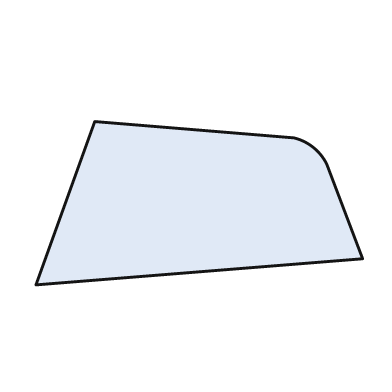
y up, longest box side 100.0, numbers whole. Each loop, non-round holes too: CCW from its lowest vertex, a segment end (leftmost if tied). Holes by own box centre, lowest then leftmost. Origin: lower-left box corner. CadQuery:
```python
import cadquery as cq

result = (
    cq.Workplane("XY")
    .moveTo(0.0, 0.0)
    .lineTo(100.0, 8.0)
    .lineTo(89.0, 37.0)
    .threePointArc((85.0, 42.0), (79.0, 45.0))
    .lineTo(18.0, 50.0)
    .close()
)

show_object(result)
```